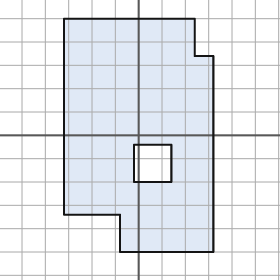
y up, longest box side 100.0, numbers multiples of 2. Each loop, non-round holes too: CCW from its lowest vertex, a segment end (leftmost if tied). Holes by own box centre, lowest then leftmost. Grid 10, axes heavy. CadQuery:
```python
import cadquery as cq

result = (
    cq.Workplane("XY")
    .moveTo(-8.0, -50.0)
    .lineTo(32.0, -50.0)
    .lineTo(32.0, 34.0)
    .lineTo(24.0, 34.0)
    .lineTo(24.0, 50.0)
    .lineTo(-32.0, 50.0)
    .lineTo(-32.0, -34.0)
    .lineTo(-8.0, -34.0)
    .close()
    .moveTo(-2.0, -20.0)
    .lineTo(14.0, -20.0)
    .lineTo(14.0, -4.0)
    .lineTo(-2.0, -4.0)
    .close()
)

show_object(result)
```